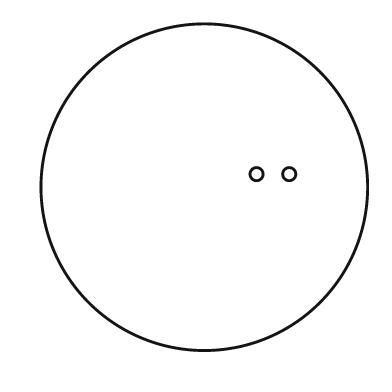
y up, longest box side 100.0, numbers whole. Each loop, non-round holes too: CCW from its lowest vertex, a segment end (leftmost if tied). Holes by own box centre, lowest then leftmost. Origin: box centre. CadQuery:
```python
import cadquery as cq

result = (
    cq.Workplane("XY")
    .moveTo(0.0, 0.0)
    .circle(50.0)
    .moveTo(16.0, 4.0)
    .circle(2.0)
    .moveTo(26.0, 4.0)
    .circle(2.0)
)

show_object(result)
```